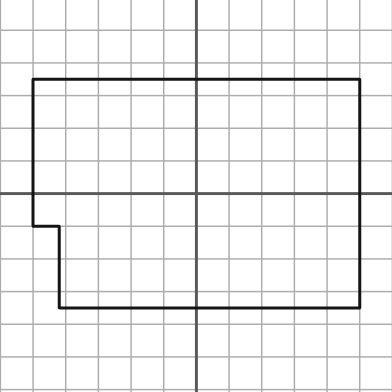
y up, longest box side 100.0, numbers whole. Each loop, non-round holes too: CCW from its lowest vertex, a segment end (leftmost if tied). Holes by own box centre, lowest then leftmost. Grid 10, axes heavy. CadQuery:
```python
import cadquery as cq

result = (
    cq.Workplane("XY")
    .moveTo(-42.0, -35.0)
    .lineTo(50.0, -35.0)
    .lineTo(50.0, 35.0)
    .lineTo(-50.0, 35.0)
    .lineTo(-50.0, -10.0)
    .lineTo(-42.0, -10.0)
    .close()
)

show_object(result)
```